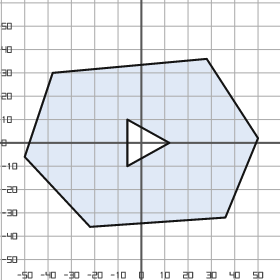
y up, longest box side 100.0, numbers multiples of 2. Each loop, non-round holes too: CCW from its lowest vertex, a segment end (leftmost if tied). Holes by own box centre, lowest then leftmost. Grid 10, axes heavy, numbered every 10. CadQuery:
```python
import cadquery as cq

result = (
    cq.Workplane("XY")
    .moveTo(-22.0, -36.0)
    .lineTo(36.0, -32.0)
    .lineTo(50.0, 2.0)
    .lineTo(28.0, 36.0)
    .lineTo(-38.0, 30.0)
    .lineTo(-50.0, -6.0)
    .close()
    .moveTo(-6.0, -10.0)
    .lineTo(12.0, 0.0)
    .lineTo(-6.0, 10.0)
    .close()
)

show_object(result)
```